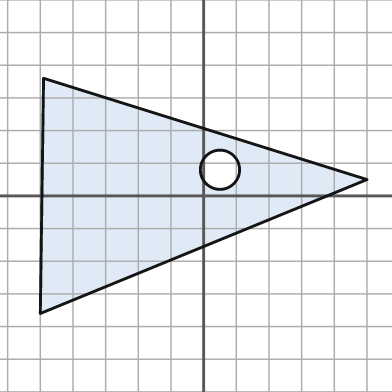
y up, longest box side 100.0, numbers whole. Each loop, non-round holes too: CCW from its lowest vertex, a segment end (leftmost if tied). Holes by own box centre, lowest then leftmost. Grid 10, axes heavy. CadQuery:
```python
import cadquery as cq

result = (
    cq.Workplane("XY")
    .moveTo(-50.0, -36.0)
    .lineTo(50.0, 5.0)
    .lineTo(-49.0, 36.0)
    .close()
    .moveTo(5.0, 8.0)
    .circle(6.0)
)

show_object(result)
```